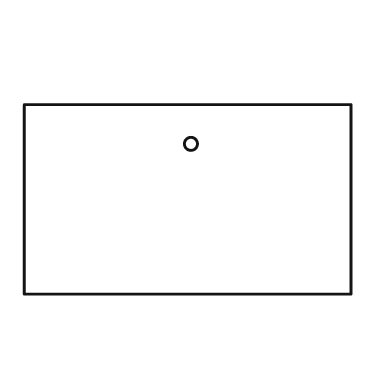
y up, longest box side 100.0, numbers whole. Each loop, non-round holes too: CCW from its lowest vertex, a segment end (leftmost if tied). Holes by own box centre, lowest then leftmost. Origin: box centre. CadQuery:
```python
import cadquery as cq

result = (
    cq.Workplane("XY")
    .moveTo(-50.0, -29.0)
    .lineTo(50.0, -29.0)
    .lineTo(50.0, 29.0)
    .lineTo(-50.0, 29.0)
    .close()
    .moveTo(1.0, 17.0)
    .circle(2.0)
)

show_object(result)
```